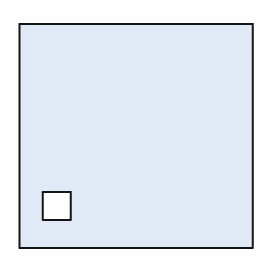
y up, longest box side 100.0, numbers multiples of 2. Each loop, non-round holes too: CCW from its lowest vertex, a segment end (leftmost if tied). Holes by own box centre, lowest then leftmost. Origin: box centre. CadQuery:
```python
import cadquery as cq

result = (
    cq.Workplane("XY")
    .moveTo(-50.0, -48.0)
    .lineTo(50.0, -48.0)
    .lineTo(50.0, 48.0)
    .lineTo(-50.0, 48.0)
    .close()
    .moveTo(-40.0, -36.0)
    .lineTo(-28.0, -36.0)
    .lineTo(-28.0, -24.0)
    .lineTo(-40.0, -24.0)
    .close()
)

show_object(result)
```